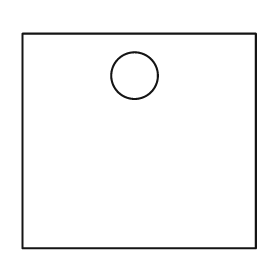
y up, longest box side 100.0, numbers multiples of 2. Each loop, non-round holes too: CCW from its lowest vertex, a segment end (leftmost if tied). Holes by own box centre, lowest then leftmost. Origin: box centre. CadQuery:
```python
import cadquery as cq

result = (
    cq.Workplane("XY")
    .moveTo(-50.0, -46.0)
    .lineTo(50.0, -46.0)
    .lineTo(50.0, 46.0)
    .lineTo(-50.0, 46.0)
    .close()
    .moveTo(-2.0, 28.0)
    .circle(10.0)
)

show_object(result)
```